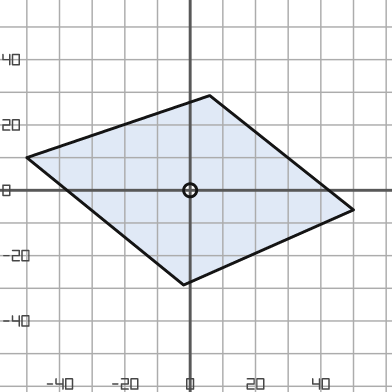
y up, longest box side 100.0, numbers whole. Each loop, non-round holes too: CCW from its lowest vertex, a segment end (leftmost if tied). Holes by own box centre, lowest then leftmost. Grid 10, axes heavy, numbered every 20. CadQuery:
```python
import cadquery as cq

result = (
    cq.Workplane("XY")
    .moveTo(-2.0, -29.0)
    .lineTo(50.0, -6.0)
    .lineTo(6.0, 29.0)
    .lineTo(-50.0, 10.0)
    .close()
    .moveTo(0.0, 0.0)
    .circle(2.0)
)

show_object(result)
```